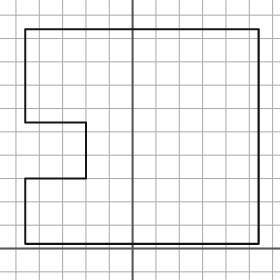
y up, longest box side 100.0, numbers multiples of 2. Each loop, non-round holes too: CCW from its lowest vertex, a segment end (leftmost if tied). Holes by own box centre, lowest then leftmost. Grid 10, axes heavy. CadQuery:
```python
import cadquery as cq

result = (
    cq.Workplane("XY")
    .moveTo(-46.0, 2.0)
    .lineTo(54.0, 2.0)
    .lineTo(54.0, 94.0)
    .lineTo(-46.0, 94.0)
    .lineTo(-46.0, 54.0)
    .lineTo(-20.0, 54.0)
    .lineTo(-20.0, 30.0)
    .lineTo(-46.0, 30.0)
    .close()
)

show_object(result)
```